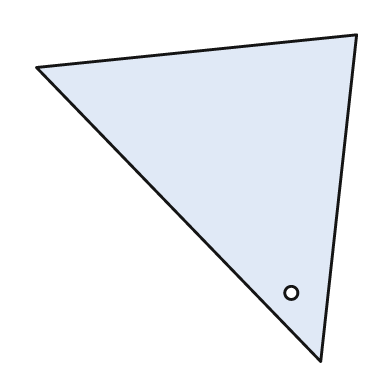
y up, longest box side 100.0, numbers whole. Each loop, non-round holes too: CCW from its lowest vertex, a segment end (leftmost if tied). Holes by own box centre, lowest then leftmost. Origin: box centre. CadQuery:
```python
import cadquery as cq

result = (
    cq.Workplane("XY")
    .moveTo(38.0, -50.0)
    .lineTo(49.0, 50.0)
    .lineTo(-49.0, 40.0)
    .close()
    .moveTo(29.0, -29.0)
    .circle(2.0)
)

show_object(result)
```